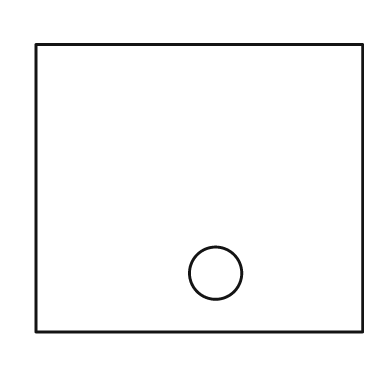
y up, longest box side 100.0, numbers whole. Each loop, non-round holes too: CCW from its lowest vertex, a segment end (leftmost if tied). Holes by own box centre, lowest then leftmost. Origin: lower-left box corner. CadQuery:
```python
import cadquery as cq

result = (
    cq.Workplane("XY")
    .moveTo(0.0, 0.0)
    .lineTo(100.0, 0.0)
    .lineTo(100.0, 88.0)
    .lineTo(0.0, 88.0)
    .close()
    .moveTo(55.0, 18.0)
    .circle(8.0)
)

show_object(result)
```